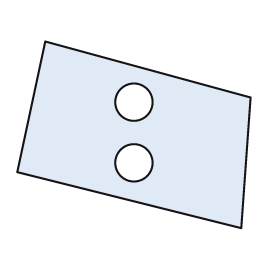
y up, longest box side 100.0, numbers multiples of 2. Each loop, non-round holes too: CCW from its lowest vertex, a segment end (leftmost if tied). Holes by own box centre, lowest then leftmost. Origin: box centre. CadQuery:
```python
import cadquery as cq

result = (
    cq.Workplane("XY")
    .moveTo(46.0, -40.0)
    .lineTo(50.0, 16.0)
    .lineTo(-38.0, 40.0)
    .lineTo(-50.0, -16.0)
    .close()
    .moveTo(0.0, -12.0)
    .circle(8.0)
    .moveTo(0.0, 14.0)
    .circle(8.0)
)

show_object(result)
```